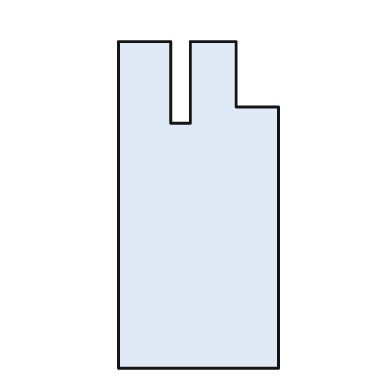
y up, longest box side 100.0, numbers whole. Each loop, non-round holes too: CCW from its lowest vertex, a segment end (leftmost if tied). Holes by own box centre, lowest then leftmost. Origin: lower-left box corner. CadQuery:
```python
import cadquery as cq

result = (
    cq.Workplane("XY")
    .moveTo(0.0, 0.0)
    .lineTo(49.0, 0.0)
    .lineTo(49.0, 80.0)
    .lineTo(36.0, 80.0)
    .lineTo(36.0, 100.0)
    .lineTo(22.0, 100.0)
    .lineTo(22.0, 75.0)
    .lineTo(16.0, 75.0)
    .lineTo(16.0, 100.0)
    .lineTo(0.0, 100.0)
    .close()
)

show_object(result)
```